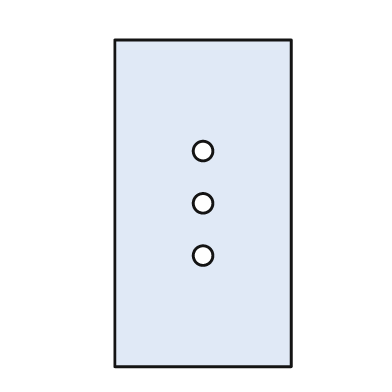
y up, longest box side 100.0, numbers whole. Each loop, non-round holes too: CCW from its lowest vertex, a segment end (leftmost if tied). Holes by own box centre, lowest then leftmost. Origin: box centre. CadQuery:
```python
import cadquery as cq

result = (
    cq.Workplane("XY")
    .moveTo(-27.0, -50.0)
    .lineTo(27.0, -50.0)
    .lineTo(27.0, 50.0)
    .lineTo(-27.0, 50.0)
    .close()
    .moveTo(0.0, -16.0)
    .circle(3.0)
    .moveTo(0.0, 0.0)
    .circle(3.0)
    .moveTo(0.0, 16.0)
    .circle(3.0)
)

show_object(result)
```